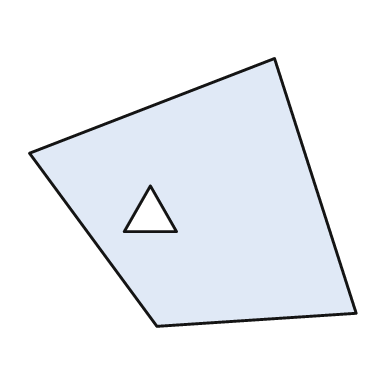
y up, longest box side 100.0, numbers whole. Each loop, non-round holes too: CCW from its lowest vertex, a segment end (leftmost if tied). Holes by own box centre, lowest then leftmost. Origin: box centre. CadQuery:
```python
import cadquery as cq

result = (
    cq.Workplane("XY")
    .moveTo(-11.0, -41.0)
    .lineTo(50.0, -37.0)
    .lineTo(25.0, 41.0)
    .lineTo(-50.0, 12.0)
    .close()
    .moveTo(-21.0, -12.0)
    .lineTo(-5.0, -12.0)
    .lineTo(-13.0, 2.0)
    .close()
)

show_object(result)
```